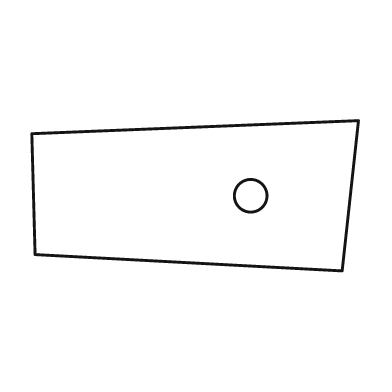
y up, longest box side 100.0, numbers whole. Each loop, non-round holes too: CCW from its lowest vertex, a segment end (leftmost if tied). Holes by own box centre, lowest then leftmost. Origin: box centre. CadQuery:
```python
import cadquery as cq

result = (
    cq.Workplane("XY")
    .moveTo(45.0, -23.0)
    .lineTo(50.0, 23.0)
    .lineTo(-50.0, 19.0)
    .lineTo(-49.0, -18.0)
    .close()
    .moveTo(17.0, 0.0)
    .circle(5.0)
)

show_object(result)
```